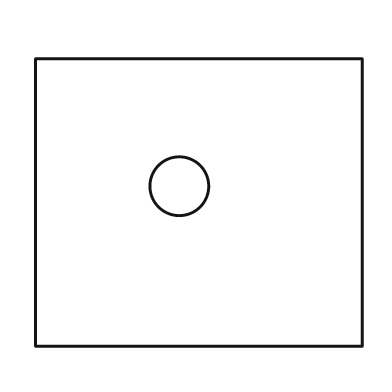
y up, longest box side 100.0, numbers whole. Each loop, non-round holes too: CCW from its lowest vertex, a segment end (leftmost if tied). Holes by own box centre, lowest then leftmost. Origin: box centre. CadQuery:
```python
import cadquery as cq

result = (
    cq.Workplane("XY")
    .moveTo(-50.0, -44.0)
    .lineTo(50.0, -44.0)
    .lineTo(50.0, 44.0)
    .lineTo(-50.0, 44.0)
    .close()
    .moveTo(-6.0, 5.0)
    .circle(9.0)
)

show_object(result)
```